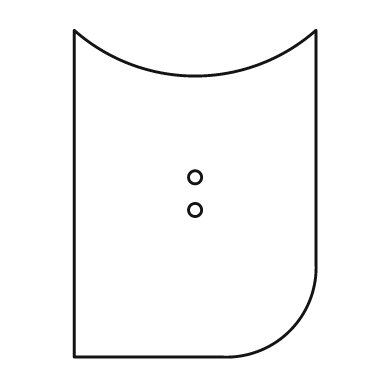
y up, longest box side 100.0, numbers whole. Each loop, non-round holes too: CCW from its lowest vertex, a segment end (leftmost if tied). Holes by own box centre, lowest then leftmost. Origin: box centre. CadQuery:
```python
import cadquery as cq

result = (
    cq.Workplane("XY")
    .moveTo(-37.0, -50.0)
    .lineTo(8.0, -50.0)
    .threePointArc((29.0, -42.0), (37.0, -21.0))
    .lineTo(37.0, 50.0)
    .threePointArc((0.0, 36.0), (-37.0, 50.0))
    .close()
    .moveTo(0.0, -5.0)
    .circle(2.0)
    .moveTo(0.0, 5.0)
    .circle(2.0)
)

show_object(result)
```